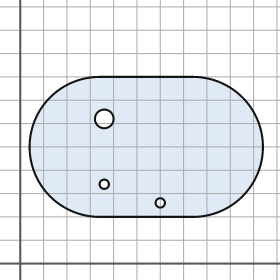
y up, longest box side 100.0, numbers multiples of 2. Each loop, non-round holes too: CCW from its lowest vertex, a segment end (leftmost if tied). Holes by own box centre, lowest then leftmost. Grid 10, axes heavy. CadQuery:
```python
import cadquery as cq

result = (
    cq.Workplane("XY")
    .moveTo(34.0, 20.0)
    .lineTo(74.0, 20.0)
    .threePointArc((104.0, 50.0), (74.0, 80.0))
    .lineTo(34.0, 80.0)
    .threePointArc((4.0, 50.0), (34.0, 20.0))
    .close()
    .moveTo(60.0, 26.0)
    .circle(2.0)
    .moveTo(36.0, 34.0)
    .circle(2.0)
    .moveTo(36.0, 62.0)
    .circle(4.0)
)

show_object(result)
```